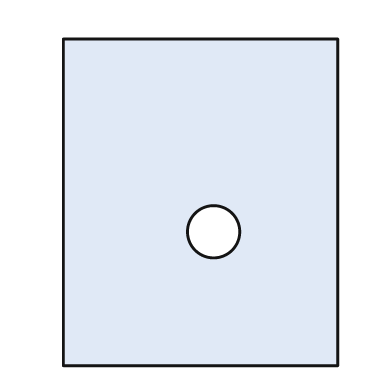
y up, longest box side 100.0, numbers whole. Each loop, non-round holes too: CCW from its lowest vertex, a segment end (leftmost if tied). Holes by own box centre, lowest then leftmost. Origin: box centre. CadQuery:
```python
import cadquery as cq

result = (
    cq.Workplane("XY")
    .moveTo(-42.0, -50.0)
    .lineTo(42.0, -50.0)
    .lineTo(42.0, 50.0)
    .lineTo(-42.0, 50.0)
    .close()
    .moveTo(4.0, -9.0)
    .circle(8.0)
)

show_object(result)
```